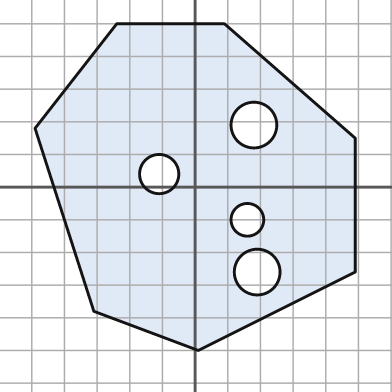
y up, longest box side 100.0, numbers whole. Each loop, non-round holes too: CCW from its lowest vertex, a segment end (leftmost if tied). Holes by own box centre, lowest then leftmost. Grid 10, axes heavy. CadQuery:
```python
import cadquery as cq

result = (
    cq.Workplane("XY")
    .moveTo(1.0, -50.0)
    .lineTo(49.0, -26.0)
    .lineTo(49.0, 15.0)
    .lineTo(9.0, 50.0)
    .lineTo(-24.0, 50.0)
    .lineTo(-49.0, 18.0)
    .lineTo(-31.0, -38.0)
    .close()
    .moveTo(19.0, -26.0)
    .circle(7.0)
    .moveTo(16.0, -10.0)
    .circle(5.0)
    .moveTo(-11.0, 4.0)
    .circle(6.0)
    .moveTo(18.0, 19.0)
    .circle(7.0)
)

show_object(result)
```